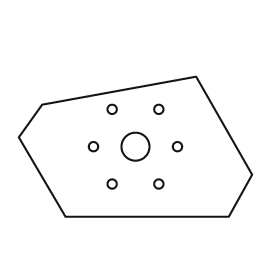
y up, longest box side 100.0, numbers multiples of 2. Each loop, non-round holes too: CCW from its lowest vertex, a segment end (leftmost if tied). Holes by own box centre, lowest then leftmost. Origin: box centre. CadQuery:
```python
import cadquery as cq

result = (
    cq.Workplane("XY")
    .moveTo(-30.0, -30.0)
    .lineTo(40.0, -30.0)
    .lineTo(50.0, -12.0)
    .lineTo(26.0, 30.0)
    .lineTo(-40.0, 18.0)
    .lineTo(-50.0, 4.0)
    .close()
    .moveTo(-10.0, -16.0)
    .circle(2.0)
    .moveTo(10.0, -16.0)
    .circle(2.0)
    .moveTo(-18.0, 0.0)
    .circle(2.0)
    .moveTo(0.0, 0.0)
    .circle(6.0)
    .moveTo(18.0, 0.0)
    .circle(2.0)
    .moveTo(-10.0, 16.0)
    .circle(2.0)
    .moveTo(10.0, 16.0)
    .circle(2.0)
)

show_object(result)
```